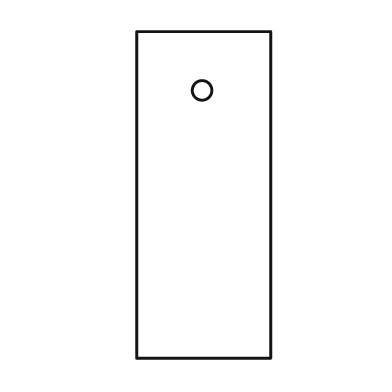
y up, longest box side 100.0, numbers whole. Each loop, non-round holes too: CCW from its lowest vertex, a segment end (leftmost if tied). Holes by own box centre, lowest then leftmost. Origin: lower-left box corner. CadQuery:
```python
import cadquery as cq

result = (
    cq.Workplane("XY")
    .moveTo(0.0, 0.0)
    .lineTo(41.0, 0.0)
    .lineTo(41.0, 100.0)
    .lineTo(0.0, 100.0)
    .close()
    .moveTo(20.0, 82.0)
    .circle(3.0)
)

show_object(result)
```